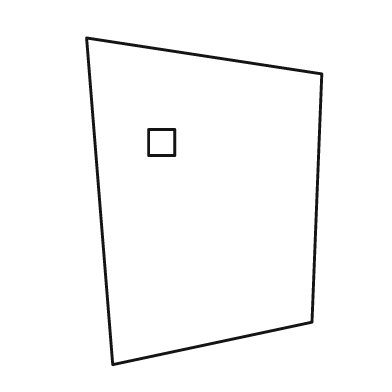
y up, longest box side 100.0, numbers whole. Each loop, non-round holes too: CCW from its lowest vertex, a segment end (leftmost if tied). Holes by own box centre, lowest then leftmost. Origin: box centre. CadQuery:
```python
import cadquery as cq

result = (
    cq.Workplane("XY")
    .moveTo(-28.0, -50.0)
    .lineTo(33.0, -37.0)
    .lineTo(36.0, 39.0)
    .lineTo(-36.0, 50.0)
    .close()
    .moveTo(-17.0, 14.0)
    .lineTo(-9.0, 14.0)
    .lineTo(-9.0, 22.0)
    .lineTo(-17.0, 22.0)
    .close()
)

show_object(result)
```